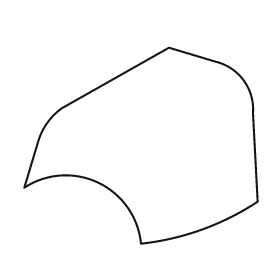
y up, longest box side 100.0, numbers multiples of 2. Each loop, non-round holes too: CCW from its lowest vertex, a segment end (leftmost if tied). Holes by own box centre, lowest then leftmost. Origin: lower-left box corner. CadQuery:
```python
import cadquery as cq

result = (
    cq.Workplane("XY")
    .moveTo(50.0, 0.0)
    .threePointArc((76.0, 6.0), (100.0, 18.0))
    .lineTo(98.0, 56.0)
    .threePointArc((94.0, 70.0), (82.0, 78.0))
    .lineTo(62.0, 84.0)
    .lineTo(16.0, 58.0)
    .threePointArc((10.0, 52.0), (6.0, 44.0))
    .lineTo(0.0, 24.0)
    .threePointArc((32.0, 26.0), (50.0, 0.0))
    .close()
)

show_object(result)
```